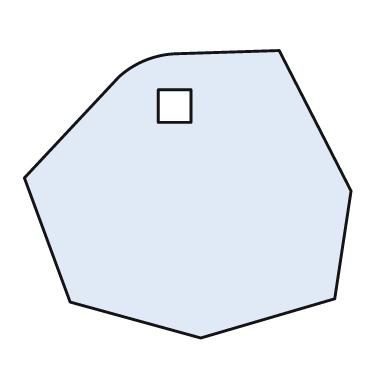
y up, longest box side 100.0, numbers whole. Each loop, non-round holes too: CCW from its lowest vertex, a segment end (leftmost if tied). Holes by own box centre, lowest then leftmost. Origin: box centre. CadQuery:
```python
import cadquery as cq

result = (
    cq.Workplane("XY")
    .moveTo(4.0, -44.0)
    .lineTo(45.0, -32.0)
    .lineTo(50.0, 1.0)
    .lineTo(28.0, 44.0)
    .lineTo(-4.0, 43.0)
    .threePointArc((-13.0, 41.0), (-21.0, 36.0))
    .lineTo(-50.0, 5.0)
    .lineTo(-36.0, -33.0)
    .close()
    .moveTo(-9.0, 22.0)
    .lineTo(1.0, 22.0)
    .lineTo(1.0, 32.0)
    .lineTo(-9.0, 32.0)
    .close()
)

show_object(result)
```